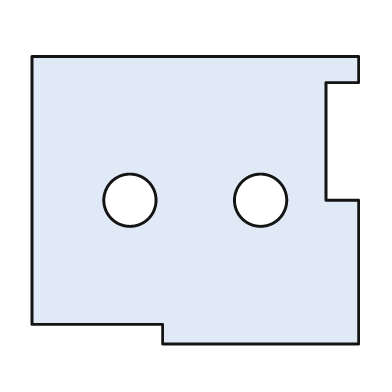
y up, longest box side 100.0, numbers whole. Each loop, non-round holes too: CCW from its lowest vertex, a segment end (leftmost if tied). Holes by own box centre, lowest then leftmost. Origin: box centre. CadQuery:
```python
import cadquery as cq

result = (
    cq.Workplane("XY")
    .moveTo(-10.0, -44.0)
    .lineTo(50.0, -44.0)
    .lineTo(50.0, 0.0)
    .lineTo(40.0, 0.0)
    .lineTo(40.0, 36.0)
    .lineTo(50.0, 36.0)
    .lineTo(50.0, 44.0)
    .lineTo(-50.0, 44.0)
    .lineTo(-50.0, -38.0)
    .lineTo(-10.0, -38.0)
    .close()
    .moveTo(-20.0, 0.0)
    .circle(8.0)
    .moveTo(20.0, 0.0)
    .circle(8.0)
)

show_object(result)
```